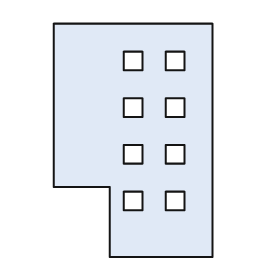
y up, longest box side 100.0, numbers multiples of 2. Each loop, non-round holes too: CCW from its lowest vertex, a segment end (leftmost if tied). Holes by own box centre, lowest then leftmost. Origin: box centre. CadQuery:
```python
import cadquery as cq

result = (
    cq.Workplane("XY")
    .moveTo(-10.0, -50.0)
    .lineTo(34.0, -50.0)
    .lineTo(34.0, 50.0)
    .lineTo(-34.0, 50.0)
    .lineTo(-34.0, -20.0)
    .lineTo(-10.0, -20.0)
    .close()
    .moveTo(-4.0, -30.0)
    .lineTo(4.0, -30.0)
    .lineTo(4.0, -22.0)
    .lineTo(-4.0, -22.0)
    .close()
    .moveTo(14.0, -30.0)
    .lineTo(22.0, -30.0)
    .lineTo(22.0, -22.0)
    .lineTo(14.0, -22.0)
    .close()
    .moveTo(-4.0, -10.0)
    .lineTo(4.0, -10.0)
    .lineTo(4.0, -2.0)
    .lineTo(-4.0, -2.0)
    .close()
    .moveTo(14.0, -10.0)
    .lineTo(22.0, -10.0)
    .lineTo(22.0, -2.0)
    .lineTo(14.0, -2.0)
    .close()
    .moveTo(-4.0, 10.0)
    .lineTo(4.0, 10.0)
    .lineTo(4.0, 18.0)
    .lineTo(-4.0, 18.0)
    .close()
    .moveTo(14.0, 10.0)
    .lineTo(22.0, 10.0)
    .lineTo(22.0, 18.0)
    .lineTo(14.0, 18.0)
    .close()
    .moveTo(-4.0, 30.0)
    .lineTo(4.0, 30.0)
    .lineTo(4.0, 38.0)
    .lineTo(-4.0, 38.0)
    .close()
    .moveTo(14.0, 30.0)
    .lineTo(22.0, 30.0)
    .lineTo(22.0, 38.0)
    .lineTo(14.0, 38.0)
    .close()
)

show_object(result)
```